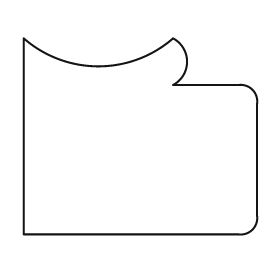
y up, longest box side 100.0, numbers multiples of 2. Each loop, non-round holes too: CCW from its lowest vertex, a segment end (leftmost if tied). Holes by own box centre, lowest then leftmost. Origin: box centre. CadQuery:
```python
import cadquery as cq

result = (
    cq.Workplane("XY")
    .moveTo(-50.0, -42.0)
    .lineTo(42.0, -42.0)
    .threePointArc((48.0, -40.0), (50.0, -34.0))
    .lineTo(50.0, 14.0)
    .threePointArc((48.0, 20.0), (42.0, 22.0))
    .lineTo(14.0, 22.0)
    .threePointArc((20.0, 32.0), (14.0, 42.0))
    .threePointArc((-18.0, 30.0), (-50.0, 42.0))
    .close()
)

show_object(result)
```